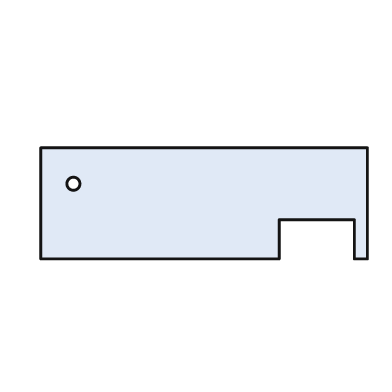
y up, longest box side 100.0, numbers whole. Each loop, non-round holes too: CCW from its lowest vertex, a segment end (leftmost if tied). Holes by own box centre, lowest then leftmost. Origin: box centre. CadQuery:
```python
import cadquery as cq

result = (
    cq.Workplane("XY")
    .moveTo(-50.0, -17.0)
    .lineTo(23.0, -17.0)
    .lineTo(23.0, -5.0)
    .lineTo(46.0, -5.0)
    .lineTo(46.0, -17.0)
    .lineTo(50.0, -17.0)
    .lineTo(50.0, 17.0)
    .lineTo(-50.0, 17.0)
    .close()
    .moveTo(-40.0, 6.0)
    .circle(2.0)
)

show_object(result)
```